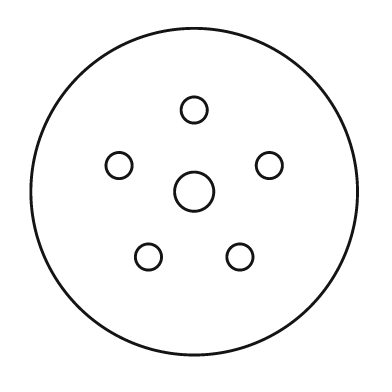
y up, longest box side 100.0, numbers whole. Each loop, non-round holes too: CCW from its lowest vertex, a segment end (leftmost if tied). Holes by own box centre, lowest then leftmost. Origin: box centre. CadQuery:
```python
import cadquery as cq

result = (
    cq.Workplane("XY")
    .moveTo(0.0, 0.0)
    .circle(50.0)
    .moveTo(-14.0, -20.0)
    .circle(4.0)
    .moveTo(14.0, -20.0)
    .circle(4.0)
    .moveTo(0.0, 0.0)
    .circle(6.0)
    .moveTo(-23.0, 8.0)
    .circle(4.0)
    .moveTo(23.0, 8.0)
    .circle(4.0)
    .moveTo(0.0, 25.0)
    .circle(4.0)
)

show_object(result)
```